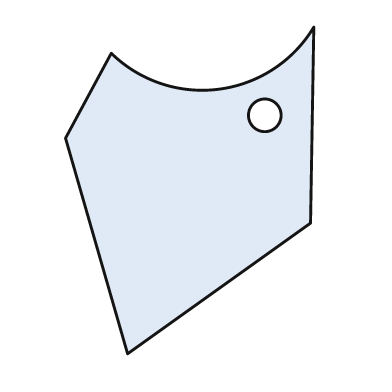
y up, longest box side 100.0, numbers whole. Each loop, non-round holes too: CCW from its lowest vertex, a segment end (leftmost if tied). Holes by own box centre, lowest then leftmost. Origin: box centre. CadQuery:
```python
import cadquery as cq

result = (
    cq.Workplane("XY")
    .moveTo(-19.0, -50.0)
    .lineTo(37.0, -10.0)
    .lineTo(38.0, 50.0)
    .threePointArc((9.0, 31.0), (-24.0, 42.0))
    .lineTo(-38.0, 16.0)
    .close()
    .moveTo(23.0, 23.0)
    .circle(5.0)
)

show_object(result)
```